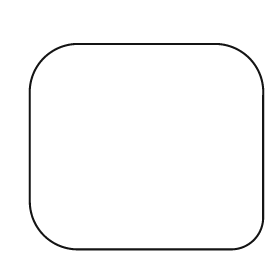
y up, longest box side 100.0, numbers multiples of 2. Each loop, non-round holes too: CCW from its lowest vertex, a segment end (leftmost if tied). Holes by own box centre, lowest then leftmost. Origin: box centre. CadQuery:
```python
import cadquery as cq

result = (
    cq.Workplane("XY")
    .moveTo(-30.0, -44.0)
    .lineTo(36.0, -44.0)
    .threePointArc((46.0, -40.0), (50.0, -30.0))
    .lineTo(50.0, 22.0)
    .threePointArc((44.0, 38.0), (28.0, 44.0))
    .lineTo(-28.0, 44.0)
    .threePointArc((-44.0, 38.0), (-50.0, 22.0))
    .lineTo(-50.0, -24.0)
    .threePointArc((-44.0, -38.0), (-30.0, -44.0))
    .close()
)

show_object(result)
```